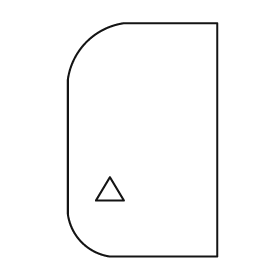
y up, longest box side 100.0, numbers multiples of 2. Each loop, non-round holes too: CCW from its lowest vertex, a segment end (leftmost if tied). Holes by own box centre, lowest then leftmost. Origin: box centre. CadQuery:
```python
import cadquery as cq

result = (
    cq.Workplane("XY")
    .moveTo(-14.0, -50.0)
    .lineTo(32.0, -50.0)
    .lineTo(32.0, 50.0)
    .lineTo(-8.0, 50.0)
    .threePointArc((-24.0, 42.0), (-32.0, 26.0))
    .lineTo(-32.0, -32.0)
    .threePointArc((-26.0, -44.0), (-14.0, -50.0))
    .close()
    .moveTo(-20.0, -26.0)
    .lineTo(-8.0, -26.0)
    .lineTo(-14.0, -16.0)
    .close()
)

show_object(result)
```